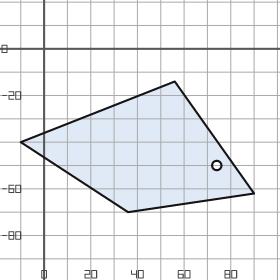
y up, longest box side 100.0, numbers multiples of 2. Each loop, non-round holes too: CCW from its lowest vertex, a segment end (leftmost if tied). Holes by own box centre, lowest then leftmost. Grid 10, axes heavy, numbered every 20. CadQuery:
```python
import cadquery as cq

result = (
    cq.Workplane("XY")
    .moveTo(36.0, -70.0)
    .lineTo(90.0, -62.0)
    .lineTo(56.0, -14.0)
    .lineTo(-10.0, -40.0)
    .close()
    .moveTo(74.0, -50.0)
    .circle(2.0)
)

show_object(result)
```